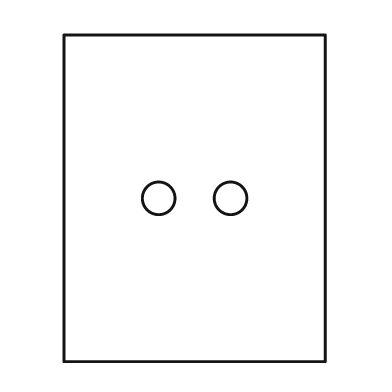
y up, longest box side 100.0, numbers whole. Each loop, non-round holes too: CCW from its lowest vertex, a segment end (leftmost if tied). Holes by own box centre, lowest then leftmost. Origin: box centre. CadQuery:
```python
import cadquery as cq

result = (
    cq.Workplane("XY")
    .moveTo(-40.0, -50.0)
    .lineTo(40.0, -50.0)
    .lineTo(40.0, 50.0)
    .lineTo(-40.0, 50.0)
    .close()
    .moveTo(-11.0, 0.0)
    .circle(5.0)
    .moveTo(11.0, 0.0)
    .circle(5.0)
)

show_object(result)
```